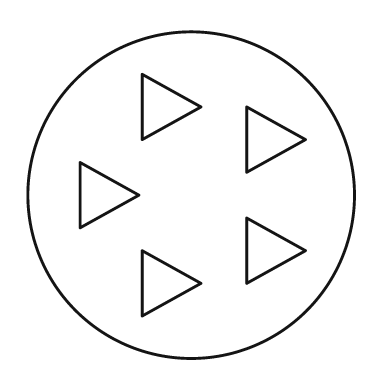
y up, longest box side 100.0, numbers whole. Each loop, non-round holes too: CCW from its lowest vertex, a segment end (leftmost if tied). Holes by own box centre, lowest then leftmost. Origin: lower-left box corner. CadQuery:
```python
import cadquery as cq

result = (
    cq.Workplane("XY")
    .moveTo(50.0, 50.0)
    .circle(50.0)
    .moveTo(35.0, 13.0)
    .lineTo(53.0, 23.0)
    .lineTo(35.0, 33.0)
    .close()
    .moveTo(67.0, 23.0)
    .lineTo(85.0, 33.0)
    .lineTo(67.0, 43.0)
    .close()
    .moveTo(16.0, 40.0)
    .lineTo(34.0, 50.0)
    .lineTo(16.0, 60.0)
    .close()
    .moveTo(67.0, 57.0)
    .lineTo(85.0, 67.0)
    .lineTo(67.0, 77.0)
    .close()
    .moveTo(35.0, 67.0)
    .lineTo(53.0, 77.0)
    .lineTo(35.0, 87.0)
    .close()
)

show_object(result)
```